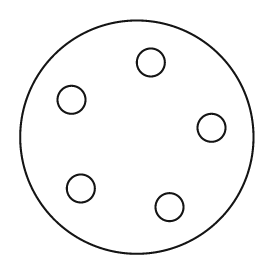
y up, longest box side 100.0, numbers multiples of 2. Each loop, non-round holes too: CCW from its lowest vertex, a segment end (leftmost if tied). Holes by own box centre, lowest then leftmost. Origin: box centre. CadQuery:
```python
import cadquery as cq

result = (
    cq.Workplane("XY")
    .moveTo(0.0, 0.0)
    .circle(50.0)
    .moveTo(14.0, -30.0)
    .circle(6.0)
    .moveTo(-24.0, -22.0)
    .circle(6.0)
    .moveTo(32.0, 4.0)
    .circle(6.0)
    .moveTo(-28.0, 16.0)
    .circle(6.0)
    .moveTo(6.0, 32.0)
    .circle(6.0)
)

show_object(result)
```